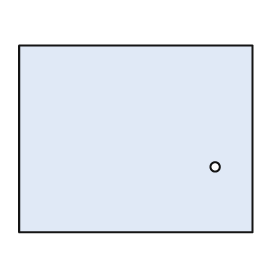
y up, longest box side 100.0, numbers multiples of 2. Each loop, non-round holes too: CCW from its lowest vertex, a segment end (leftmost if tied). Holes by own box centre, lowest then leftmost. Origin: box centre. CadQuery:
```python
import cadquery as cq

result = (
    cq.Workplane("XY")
    .moveTo(-50.0, -40.0)
    .lineTo(50.0, -40.0)
    .lineTo(50.0, 40.0)
    .lineTo(-50.0, 40.0)
    .close()
    .moveTo(34.0, -12.0)
    .circle(2.0)
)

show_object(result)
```